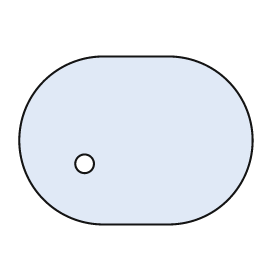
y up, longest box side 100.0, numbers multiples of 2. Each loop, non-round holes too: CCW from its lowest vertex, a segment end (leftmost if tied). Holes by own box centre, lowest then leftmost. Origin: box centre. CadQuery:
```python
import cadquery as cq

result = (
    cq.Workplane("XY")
    .moveTo(-14.0, -36.0)
    .lineTo(14.0, -36.0)
    .threePointArc((50.0, 0.0), (14.0, 36.0))
    .lineTo(-14.0, 36.0)
    .threePointArc((-50.0, 0.0), (-14.0, -36.0))
    .close()
    .moveTo(-22.0, -10.0)
    .circle(4.0)
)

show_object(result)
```